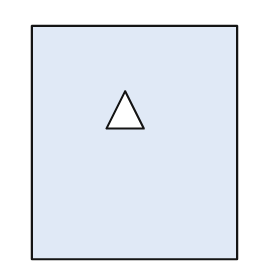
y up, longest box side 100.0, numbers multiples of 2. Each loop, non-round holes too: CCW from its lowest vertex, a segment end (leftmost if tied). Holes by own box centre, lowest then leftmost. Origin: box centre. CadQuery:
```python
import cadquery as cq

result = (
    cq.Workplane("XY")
    .moveTo(-44.0, -50.0)
    .lineTo(44.0, -50.0)
    .lineTo(44.0, 50.0)
    .lineTo(-44.0, 50.0)
    .close()
    .moveTo(-12.0, 6.0)
    .lineTo(4.0, 6.0)
    .lineTo(-4.0, 22.0)
    .close()
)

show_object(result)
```